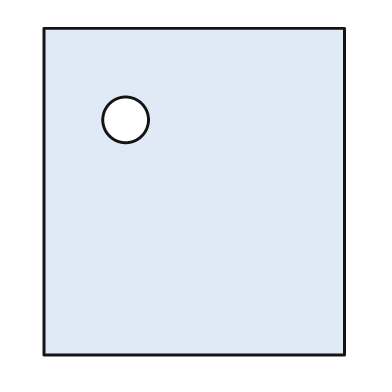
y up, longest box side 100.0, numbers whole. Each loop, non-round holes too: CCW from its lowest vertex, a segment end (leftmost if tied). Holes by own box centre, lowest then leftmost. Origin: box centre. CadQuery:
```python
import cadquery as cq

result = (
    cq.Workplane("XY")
    .moveTo(-46.0, -50.0)
    .lineTo(46.0, -50.0)
    .lineTo(46.0, 50.0)
    .lineTo(-46.0, 50.0)
    .close()
    .moveTo(-21.0, 22.0)
    .circle(7.0)
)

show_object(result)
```